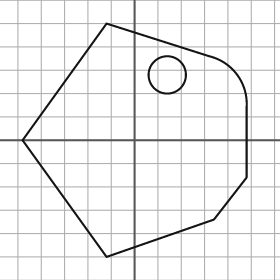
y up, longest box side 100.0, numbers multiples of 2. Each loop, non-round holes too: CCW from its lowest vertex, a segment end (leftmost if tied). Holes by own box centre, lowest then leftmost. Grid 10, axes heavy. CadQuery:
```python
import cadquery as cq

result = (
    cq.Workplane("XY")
    .moveTo(-12.0, -50.0)
    .lineTo(34.0, -34.0)
    .lineTo(48.0, -16.0)
    .lineTo(48.0, 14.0)
    .threePointArc((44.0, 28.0), (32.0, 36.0))
    .lineTo(-12.0, 50.0)
    .lineTo(-48.0, 0.0)
    .close()
    .moveTo(14.0, 28.0)
    .circle(8.0)
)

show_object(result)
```